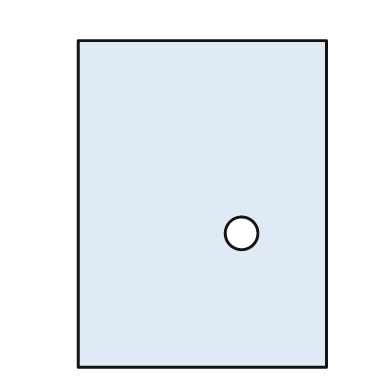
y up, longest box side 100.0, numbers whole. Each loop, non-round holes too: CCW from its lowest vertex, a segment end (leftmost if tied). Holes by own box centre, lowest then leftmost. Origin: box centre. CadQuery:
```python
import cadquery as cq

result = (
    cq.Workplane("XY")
    .moveTo(-38.0, -50.0)
    .lineTo(38.0, -50.0)
    .lineTo(38.0, 50.0)
    .lineTo(-38.0, 50.0)
    .close()
    .moveTo(12.0, -9.0)
    .circle(5.0)
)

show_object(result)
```